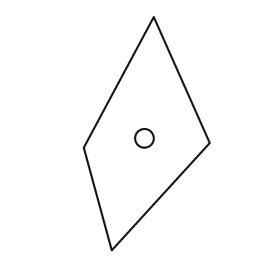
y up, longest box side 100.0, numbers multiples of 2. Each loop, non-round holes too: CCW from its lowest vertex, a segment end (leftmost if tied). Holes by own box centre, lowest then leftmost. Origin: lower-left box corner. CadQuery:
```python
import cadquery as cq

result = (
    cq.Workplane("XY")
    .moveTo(12.0, 0.0)
    .lineTo(54.0, 46.0)
    .lineTo(30.0, 100.0)
    .lineTo(0.0, 44.0)
    .close()
    .moveTo(26.0, 48.0)
    .circle(4.0)
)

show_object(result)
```